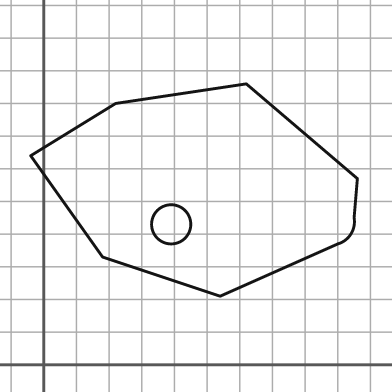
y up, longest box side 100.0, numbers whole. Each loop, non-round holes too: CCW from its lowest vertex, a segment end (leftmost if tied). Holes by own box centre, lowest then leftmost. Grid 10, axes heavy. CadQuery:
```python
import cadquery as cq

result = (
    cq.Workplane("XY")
    .moveTo(54.0, 21.0)
    .lineTo(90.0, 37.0)
    .threePointArc((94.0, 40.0), (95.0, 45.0))
    .lineTo(96.0, 57.0)
    .lineTo(62.0, 86.0)
    .lineTo(22.0, 80.0)
    .lineTo(-4.0, 64.0)
    .lineTo(18.0, 33.0)
    .close()
    .moveTo(39.0, 43.0)
    .circle(6.0)
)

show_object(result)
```